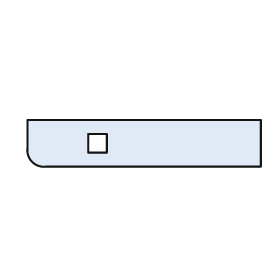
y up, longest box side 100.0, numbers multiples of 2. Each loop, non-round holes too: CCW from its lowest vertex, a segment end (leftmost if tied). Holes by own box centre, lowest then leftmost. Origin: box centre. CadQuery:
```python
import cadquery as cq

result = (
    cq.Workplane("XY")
    .moveTo(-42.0, -10.0)
    .lineTo(50.0, -10.0)
    .lineTo(50.0, 10.0)
    .lineTo(-50.0, 10.0)
    .lineTo(-50.0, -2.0)
    .threePointArc((-48.0, -8.0), (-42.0, -10.0))
    .close()
    .moveTo(-24.0, -4.0)
    .lineTo(-16.0, -4.0)
    .lineTo(-16.0, 4.0)
    .lineTo(-24.0, 4.0)
    .close()
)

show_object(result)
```